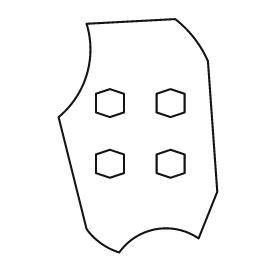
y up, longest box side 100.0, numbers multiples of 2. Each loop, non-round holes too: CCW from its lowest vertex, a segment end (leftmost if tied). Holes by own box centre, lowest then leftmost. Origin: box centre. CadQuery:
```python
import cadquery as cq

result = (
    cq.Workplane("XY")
    .moveTo(-8.0, -50.0)
    .threePointArc((8.0, -40.0), (26.0, -44.0))
    .lineTo(34.0, -24.0)
    .lineTo(30.0, 32.0)
    .threePointArc((24.0, 42.0), (16.0, 50.0))
    .lineTo(-22.0, 48.0)
    .threePointArc((-22.0, 26.0), (-34.0, 8.0))
    .lineTo(-22.0, -40.0)
    .threePointArc((-16.0, -46.0), (-8.0, -50.0))
    .close()
    .moveTo(-12.0, -18.0)
    .lineTo(-6.0, -16.0)
    .lineTo(-6.0, -8.0)
    .lineTo(-12.0, -6.0)
    .lineTo(-18.0, -8.0)
    .lineTo(-18.0, -16.0)
    .close()
    .moveTo(14.0, -18.0)
    .lineTo(20.0, -16.0)
    .lineTo(20.0, -8.0)
    .lineTo(14.0, -6.0)
    .lineTo(8.0, -8.0)
    .lineTo(8.0, -16.0)
    .close()
    .moveTo(-12.0, 8.0)
    .lineTo(-6.0, 10.0)
    .lineTo(-6.0, 18.0)
    .lineTo(-12.0, 20.0)
    .lineTo(-18.0, 18.0)
    .lineTo(-18.0, 10.0)
    .close()
    .moveTo(14.0, 8.0)
    .lineTo(20.0, 10.0)
    .lineTo(20.0, 18.0)
    .lineTo(14.0, 20.0)
    .lineTo(8.0, 18.0)
    .lineTo(8.0, 10.0)
    .close()
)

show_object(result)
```